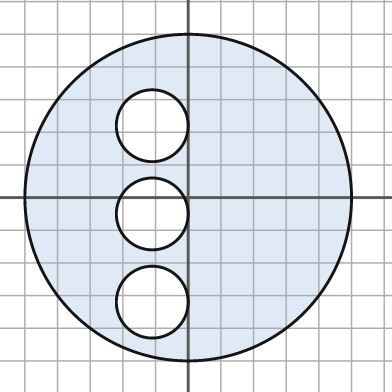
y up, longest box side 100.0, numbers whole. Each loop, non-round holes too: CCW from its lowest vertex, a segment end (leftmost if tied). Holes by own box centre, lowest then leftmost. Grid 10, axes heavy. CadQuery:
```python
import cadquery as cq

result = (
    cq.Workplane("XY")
    .moveTo(0.0, 0.0)
    .circle(50.0)
    .moveTo(-11.0, -32.0)
    .circle(11.0)
    .moveTo(-11.0, -5.0)
    .circle(11.0)
    .moveTo(-11.0, 22.0)
    .circle(11.0)
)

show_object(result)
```